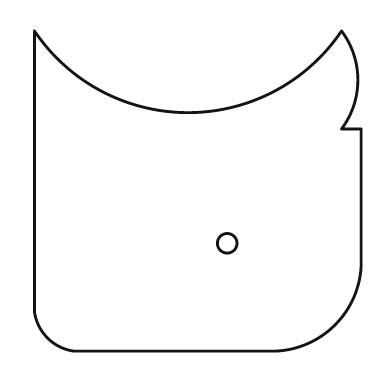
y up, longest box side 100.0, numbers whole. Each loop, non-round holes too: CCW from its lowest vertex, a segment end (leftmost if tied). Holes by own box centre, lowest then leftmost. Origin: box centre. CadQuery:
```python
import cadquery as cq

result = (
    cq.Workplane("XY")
    .moveTo(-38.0, -49.0)
    .lineTo(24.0, -49.0)
    .threePointArc((42.0, -41.0), (50.0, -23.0))
    .lineTo(50.0, 19.0)
    .lineTo(44.0, 19.0)
    .threePointArc((49.0, 34.0), (44.0, 49.0))
    .threePointArc((-3.0, 24.0), (-50.0, 49.0))
    .lineTo(-50.0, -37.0)
    .threePointArc((-46.0, -45.0), (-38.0, -49.0))
    .close()
    .moveTo(9.0, -16.0)
    .circle(3.0)
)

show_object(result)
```